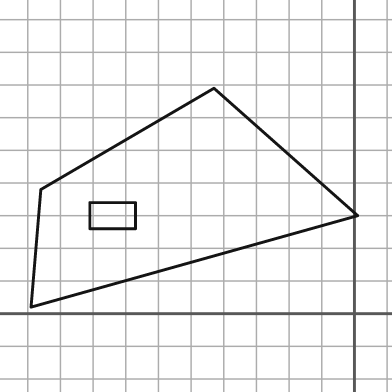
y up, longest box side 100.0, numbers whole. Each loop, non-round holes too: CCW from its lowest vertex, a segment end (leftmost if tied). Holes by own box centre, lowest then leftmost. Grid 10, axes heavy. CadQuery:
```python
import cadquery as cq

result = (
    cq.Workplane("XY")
    .moveTo(-99.0, 2.0)
    .lineTo(1.0, 30.0)
    .lineTo(-43.0, 69.0)
    .lineTo(-96.0, 38.0)
    .close()
    .moveTo(-81.0, 26.0)
    .lineTo(-67.0, 26.0)
    .lineTo(-67.0, 34.0)
    .lineTo(-81.0, 34.0)
    .close()
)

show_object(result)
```